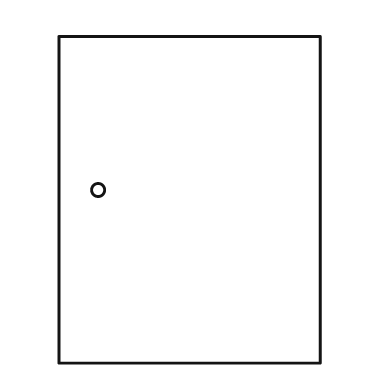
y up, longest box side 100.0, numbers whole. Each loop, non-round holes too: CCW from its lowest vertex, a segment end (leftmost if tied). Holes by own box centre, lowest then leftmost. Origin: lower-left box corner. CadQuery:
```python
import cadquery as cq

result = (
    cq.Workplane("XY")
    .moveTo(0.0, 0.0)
    .lineTo(80.0, 0.0)
    .lineTo(80.0, 100.0)
    .lineTo(0.0, 100.0)
    .close()
    .moveTo(12.0, 53.0)
    .circle(2.0)
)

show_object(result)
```